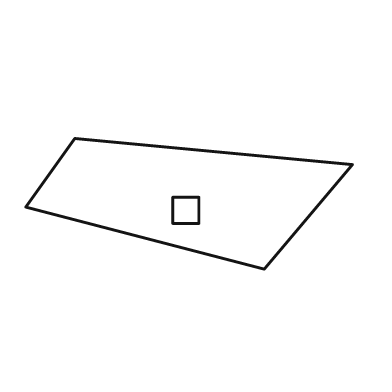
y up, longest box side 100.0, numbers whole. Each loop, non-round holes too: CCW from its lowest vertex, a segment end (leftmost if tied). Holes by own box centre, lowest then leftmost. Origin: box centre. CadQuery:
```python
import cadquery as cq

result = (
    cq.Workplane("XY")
    .moveTo(23.0, -20.0)
    .lineTo(50.0, 12.0)
    .lineTo(-35.0, 20.0)
    .lineTo(-50.0, -1.0)
    .close()
    .moveTo(-5.0, -6.0)
    .lineTo(3.0, -6.0)
    .lineTo(3.0, 2.0)
    .lineTo(-5.0, 2.0)
    .close()
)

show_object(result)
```